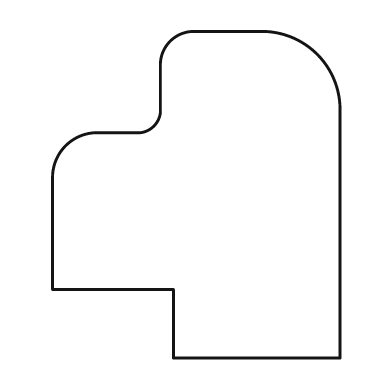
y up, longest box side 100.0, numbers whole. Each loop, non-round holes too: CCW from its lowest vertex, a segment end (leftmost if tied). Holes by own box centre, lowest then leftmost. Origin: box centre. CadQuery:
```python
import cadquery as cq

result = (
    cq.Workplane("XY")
    .moveTo(-7.0, -50.0)
    .lineTo(44.0, -50.0)
    .lineTo(44.0, 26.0)
    .threePointArc((37.0, 43.0), (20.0, 50.0))
    .lineTo(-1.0, 50.0)
    .threePointArc((-8.0, 47.0), (-11.0, 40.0))
    .lineTo(-11.0, 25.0)
    .threePointArc((-13.0, 21.0), (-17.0, 19.0))
    .lineTo(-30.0, 19.0)
    .threePointArc((-40.0, 15.0), (-44.0, 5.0))
    .lineTo(-44.0, -29.0)
    .lineTo(-7.0, -29.0)
    .close()
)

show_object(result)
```